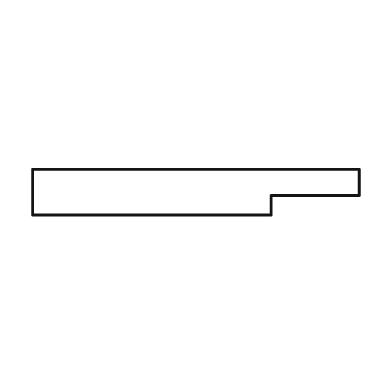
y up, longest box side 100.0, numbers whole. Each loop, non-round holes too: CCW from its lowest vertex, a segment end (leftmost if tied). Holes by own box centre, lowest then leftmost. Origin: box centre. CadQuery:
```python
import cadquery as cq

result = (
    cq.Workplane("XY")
    .moveTo(-50.0, -7.0)
    .lineTo(23.0, -7.0)
    .lineTo(23.0, -1.0)
    .lineTo(50.0, -1.0)
    .lineTo(50.0, 7.0)
    .lineTo(-50.0, 7.0)
    .close()
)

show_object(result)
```